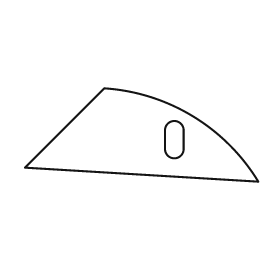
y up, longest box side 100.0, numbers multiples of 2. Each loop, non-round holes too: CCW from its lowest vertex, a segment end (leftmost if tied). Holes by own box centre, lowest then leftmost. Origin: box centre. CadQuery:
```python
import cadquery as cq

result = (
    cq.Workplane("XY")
    .moveTo(50.0, -20.0)
    .threePointArc((22.0, 8.0), (-16.0, 20.0))
    .lineTo(-50.0, -14.0)
    .close()
    .moveTo(10.0, -6.0)
    .threePointArc((14.0, -10.0), (18.0, -6.0))
    .lineTo(18.0, 2.0)
    .threePointArc((14.0, 6.0), (10.0, 2.0))
    .close()
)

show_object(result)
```